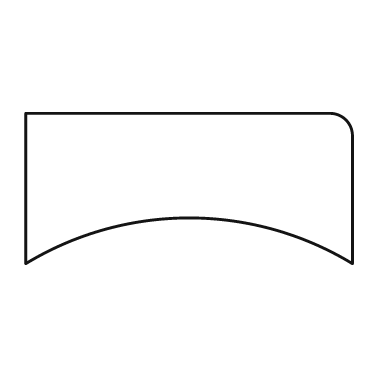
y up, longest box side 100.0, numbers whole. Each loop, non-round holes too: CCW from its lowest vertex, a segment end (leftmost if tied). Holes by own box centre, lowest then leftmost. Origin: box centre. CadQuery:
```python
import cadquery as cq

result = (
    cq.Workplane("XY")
    .moveTo(-50.0, -23.0)
    .threePointArc((0.0, -9.0), (50.0, -23.0))
    .lineTo(50.0, 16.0)
    .threePointArc((48.0, 21.0), (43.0, 23.0))
    .lineTo(-50.0, 23.0)
    .close()
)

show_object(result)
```